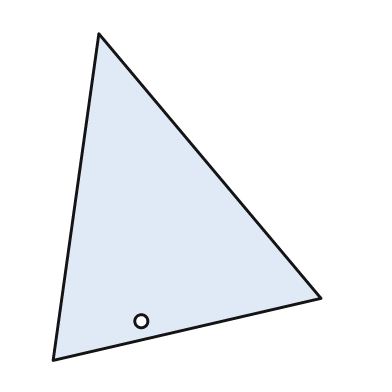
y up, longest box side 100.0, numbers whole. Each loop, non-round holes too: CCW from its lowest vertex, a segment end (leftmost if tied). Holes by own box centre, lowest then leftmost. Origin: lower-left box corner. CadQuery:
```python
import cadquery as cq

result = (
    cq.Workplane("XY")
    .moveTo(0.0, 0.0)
    .lineTo(82.0, 19.0)
    .lineTo(14.0, 100.0)
    .close()
    .moveTo(27.0, 12.0)
    .circle(2.0)
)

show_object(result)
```